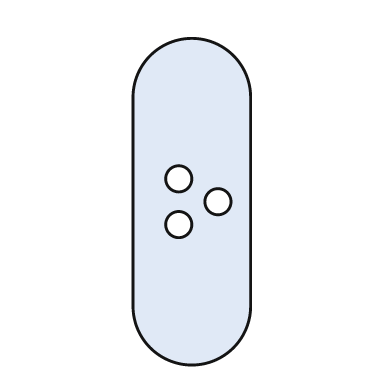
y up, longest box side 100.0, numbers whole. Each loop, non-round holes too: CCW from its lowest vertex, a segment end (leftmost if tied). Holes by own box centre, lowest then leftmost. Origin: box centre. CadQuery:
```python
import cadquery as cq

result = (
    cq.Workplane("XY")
    .moveTo(-18.0, -32.0)
    .threePointArc((0.0, -50.0), (18.0, -32.0))
    .lineTo(18.0, 32.0)
    .threePointArc((0.0, 50.0), (-18.0, 32.0))
    .close()
    .moveTo(-4.0, -7.0)
    .circle(4.0)
    .moveTo(8.0, 0.0)
    .circle(4.0)
    .moveTo(-4.0, 7.0)
    .circle(4.0)
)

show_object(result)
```